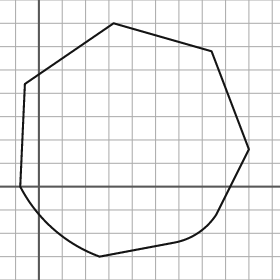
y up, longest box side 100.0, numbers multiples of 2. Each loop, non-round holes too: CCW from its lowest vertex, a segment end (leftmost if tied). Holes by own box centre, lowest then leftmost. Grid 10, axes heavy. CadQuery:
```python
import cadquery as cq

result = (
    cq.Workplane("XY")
    .moveTo(26.0, -30.0)
    .lineTo(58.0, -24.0)
    .threePointArc((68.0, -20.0), (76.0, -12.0))
    .lineTo(90.0, 16.0)
    .lineTo(74.0, 58.0)
    .lineTo(32.0, 70.0)
    .lineTo(-6.0, 44.0)
    .lineTo(-8.0, 0.0)
    .threePointArc((6.0, -18.0), (26.0, -30.0))
    .close()
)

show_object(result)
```